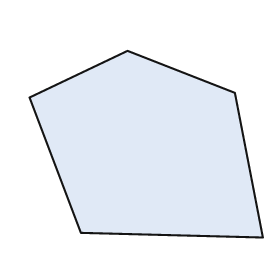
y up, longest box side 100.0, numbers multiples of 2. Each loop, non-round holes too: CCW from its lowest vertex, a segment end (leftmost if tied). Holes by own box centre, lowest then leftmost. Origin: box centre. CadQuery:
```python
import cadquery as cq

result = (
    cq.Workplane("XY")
    .moveTo(50.0, -40.0)
    .lineTo(38.0, 22.0)
    .lineTo(-8.0, 40.0)
    .lineTo(-50.0, 20.0)
    .lineTo(-28.0, -38.0)
    .close()
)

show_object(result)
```